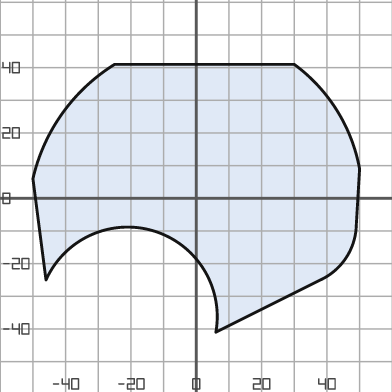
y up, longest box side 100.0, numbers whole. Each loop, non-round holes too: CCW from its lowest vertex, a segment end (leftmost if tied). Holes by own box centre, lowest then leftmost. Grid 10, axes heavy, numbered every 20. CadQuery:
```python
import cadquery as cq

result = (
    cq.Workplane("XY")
    .moveTo(6.0, -41.0)
    .lineTo(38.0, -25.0)
    .threePointArc((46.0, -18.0), (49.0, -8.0))
    .lineTo(50.0, 9.0)
    .threePointArc((43.0, 27.0), (30.0, 41.0))
    .lineTo(-25.0, 41.0)
    .threePointArc((-41.0, 26.0), (-50.0, 6.0))
    .lineTo(-46.0, -25.0)
    .threePointArc((-13.0, -10.0), (6.0, -41.0))
    .close()
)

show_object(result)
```